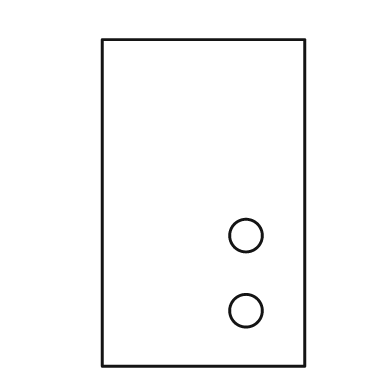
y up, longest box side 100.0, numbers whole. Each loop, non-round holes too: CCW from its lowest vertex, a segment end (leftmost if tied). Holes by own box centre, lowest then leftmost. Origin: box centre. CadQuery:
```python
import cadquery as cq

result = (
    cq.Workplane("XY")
    .moveTo(-31.0, -50.0)
    .lineTo(31.0, -50.0)
    .lineTo(31.0, 50.0)
    .lineTo(-31.0, 50.0)
    .close()
    .moveTo(13.0, -33.0)
    .circle(5.0)
    .moveTo(13.0, -10.0)
    .circle(5.0)
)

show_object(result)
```